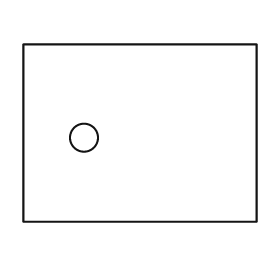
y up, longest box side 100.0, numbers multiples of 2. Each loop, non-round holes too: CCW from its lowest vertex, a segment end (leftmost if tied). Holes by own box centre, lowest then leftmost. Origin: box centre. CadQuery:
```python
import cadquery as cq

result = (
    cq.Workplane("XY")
    .moveTo(-50.0, -38.0)
    .lineTo(50.0, -38.0)
    .lineTo(50.0, 38.0)
    .lineTo(-50.0, 38.0)
    .close()
    .moveTo(-24.0, -2.0)
    .circle(6.0)
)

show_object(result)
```